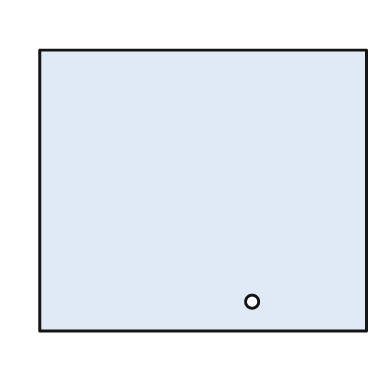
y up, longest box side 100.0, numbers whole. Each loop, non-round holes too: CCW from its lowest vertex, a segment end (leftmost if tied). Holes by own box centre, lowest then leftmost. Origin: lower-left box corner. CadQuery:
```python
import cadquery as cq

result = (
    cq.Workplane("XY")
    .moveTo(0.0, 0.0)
    .lineTo(100.0, 0.0)
    .lineTo(100.0, 86.0)
    .lineTo(0.0, 86.0)
    .close()
    .moveTo(65.0, 9.0)
    .circle(2.0)
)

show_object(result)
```